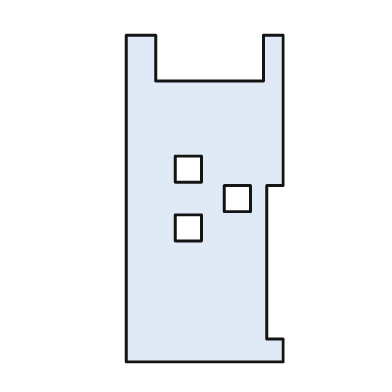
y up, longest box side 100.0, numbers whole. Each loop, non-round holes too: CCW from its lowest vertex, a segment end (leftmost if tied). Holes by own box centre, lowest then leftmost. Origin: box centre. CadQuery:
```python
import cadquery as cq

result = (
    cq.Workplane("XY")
    .moveTo(-24.0, -50.0)
    .lineTo(24.0, -50.0)
    .lineTo(24.0, -43.0)
    .lineTo(19.0, -43.0)
    .lineTo(19.0, 4.0)
    .lineTo(24.0, 4.0)
    .lineTo(24.0, 50.0)
    .lineTo(18.0, 50.0)
    .lineTo(18.0, 36.0)
    .lineTo(-15.0, 36.0)
    .lineTo(-15.0, 50.0)
    .lineTo(-24.0, 50.0)
    .close()
    .moveTo(-9.0, -13.0)
    .lineTo(-1.0, -13.0)
    .lineTo(-1.0, -5.0)
    .lineTo(-9.0, -5.0)
    .close()
    .moveTo(6.0, -4.0)
    .lineTo(14.0, -4.0)
    .lineTo(14.0, 4.0)
    .lineTo(6.0, 4.0)
    .close()
    .moveTo(-9.0, 5.0)
    .lineTo(-1.0, 5.0)
    .lineTo(-1.0, 13.0)
    .lineTo(-9.0, 13.0)
    .close()
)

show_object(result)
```